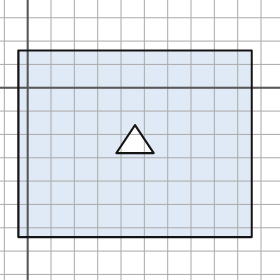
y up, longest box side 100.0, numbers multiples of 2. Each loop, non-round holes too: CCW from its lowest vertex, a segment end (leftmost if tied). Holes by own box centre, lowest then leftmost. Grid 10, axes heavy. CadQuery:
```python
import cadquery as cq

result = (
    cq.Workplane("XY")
    .moveTo(-4.0, -64.0)
    .lineTo(96.0, -64.0)
    .lineTo(96.0, 16.0)
    .lineTo(-4.0, 16.0)
    .close()
    .moveTo(38.0, -28.0)
    .lineTo(54.0, -28.0)
    .lineTo(46.0, -16.0)
    .close()
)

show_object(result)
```